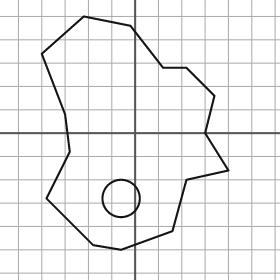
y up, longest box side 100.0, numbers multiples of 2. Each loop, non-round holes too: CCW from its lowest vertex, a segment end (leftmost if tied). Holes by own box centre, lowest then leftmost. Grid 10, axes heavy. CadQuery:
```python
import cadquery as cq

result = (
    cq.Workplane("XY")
    .moveTo(-6.0, -50.0)
    .lineTo(16.0, -42.0)
    .lineTo(22.0, -20.0)
    .lineTo(40.0, -16.0)
    .lineTo(30.0, 0.0)
    .lineTo(34.0, 16.0)
    .lineTo(22.0, 28.0)
    .lineTo(12.0, 28.0)
    .lineTo(-2.0, 46.0)
    .lineTo(-22.0, 50.0)
    .lineTo(-40.0, 34.0)
    .lineTo(-30.0, 8.0)
    .lineTo(-28.0, -8.0)
    .lineTo(-38.0, -28.0)
    .lineTo(-18.0, -48.0)
    .close()
    .moveTo(-6.0, -28.0)
    .circle(8.0)
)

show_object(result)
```